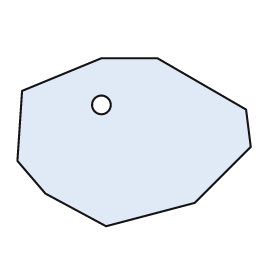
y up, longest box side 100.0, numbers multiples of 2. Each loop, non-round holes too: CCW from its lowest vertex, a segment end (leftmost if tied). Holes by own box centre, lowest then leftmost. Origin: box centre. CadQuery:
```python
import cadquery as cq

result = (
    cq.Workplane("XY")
    .moveTo(-12.0, -36.0)
    .lineTo(26.0, -26.0)
    .lineTo(50.0, -2.0)
    .lineTo(48.0, 14.0)
    .lineTo(10.0, 36.0)
    .lineTo(-14.0, 36.0)
    .lineTo(-48.0, 22.0)
    .lineTo(-50.0, -8.0)
    .lineTo(-38.0, -22.0)
    .close()
    .moveTo(-14.0, 16.0)
    .circle(4.0)
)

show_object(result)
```